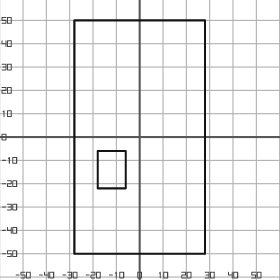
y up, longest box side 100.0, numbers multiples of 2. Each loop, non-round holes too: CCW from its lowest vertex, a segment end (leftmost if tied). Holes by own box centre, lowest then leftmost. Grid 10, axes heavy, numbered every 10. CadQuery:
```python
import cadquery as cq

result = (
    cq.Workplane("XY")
    .moveTo(-28.0, -50.0)
    .lineTo(28.0, -50.0)
    .lineTo(28.0, 50.0)
    .lineTo(-28.0, 50.0)
    .close()
    .moveTo(-18.0, -22.0)
    .lineTo(-6.0, -22.0)
    .lineTo(-6.0, -6.0)
    .lineTo(-18.0, -6.0)
    .close()
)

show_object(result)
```